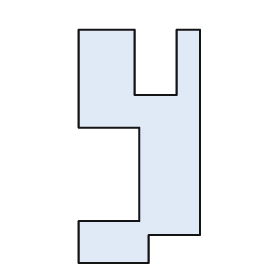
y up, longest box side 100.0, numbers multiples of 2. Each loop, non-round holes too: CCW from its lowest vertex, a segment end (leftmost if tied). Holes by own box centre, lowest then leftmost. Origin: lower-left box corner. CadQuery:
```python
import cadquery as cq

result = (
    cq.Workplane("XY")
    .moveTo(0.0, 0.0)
    .lineTo(30.0, 0.0)
    .lineTo(30.0, 12.0)
    .lineTo(52.0, 12.0)
    .lineTo(52.0, 100.0)
    .lineTo(42.0, 100.0)
    .lineTo(42.0, 72.0)
    .lineTo(24.0, 72.0)
    .lineTo(24.0, 100.0)
    .lineTo(0.0, 100.0)
    .lineTo(0.0, 58.0)
    .lineTo(26.0, 58.0)
    .lineTo(26.0, 18.0)
    .lineTo(0.0, 18.0)
    .close()
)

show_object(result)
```